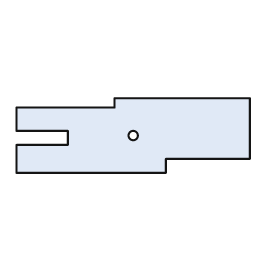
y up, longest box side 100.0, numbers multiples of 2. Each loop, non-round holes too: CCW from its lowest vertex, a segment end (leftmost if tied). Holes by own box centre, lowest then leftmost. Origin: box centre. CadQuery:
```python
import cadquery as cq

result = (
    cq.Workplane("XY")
    .moveTo(-50.0, -16.0)
    .lineTo(14.0, -16.0)
    .lineTo(14.0, -10.0)
    .lineTo(50.0, -10.0)
    .lineTo(50.0, 16.0)
    .lineTo(-8.0, 16.0)
    .lineTo(-8.0, 12.0)
    .lineTo(-50.0, 12.0)
    .lineTo(-50.0, 2.0)
    .lineTo(-28.0, 2.0)
    .lineTo(-28.0, -4.0)
    .lineTo(-50.0, -4.0)
    .close()
    .moveTo(0.0, 0.0)
    .circle(2.0)
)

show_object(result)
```